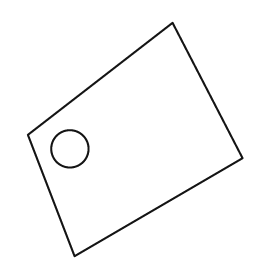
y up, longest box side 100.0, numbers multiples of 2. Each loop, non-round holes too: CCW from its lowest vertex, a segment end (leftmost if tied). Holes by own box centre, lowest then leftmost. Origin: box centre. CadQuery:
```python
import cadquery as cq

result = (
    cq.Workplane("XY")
    .moveTo(-26.0, -50.0)
    .lineTo(46.0, -8.0)
    .lineTo(16.0, 50.0)
    .lineTo(-46.0, 2.0)
    .close()
    .moveTo(-28.0, -4.0)
    .circle(8.0)
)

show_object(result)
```